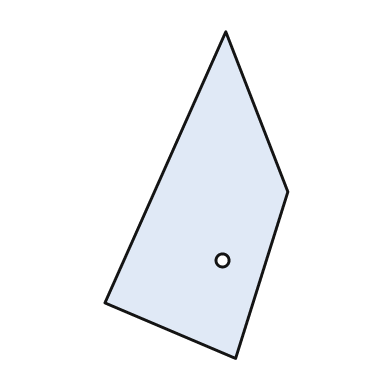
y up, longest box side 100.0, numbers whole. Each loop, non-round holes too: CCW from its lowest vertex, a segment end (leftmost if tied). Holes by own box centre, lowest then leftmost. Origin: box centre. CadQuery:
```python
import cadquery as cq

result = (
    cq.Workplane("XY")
    .moveTo(12.0, -50.0)
    .lineTo(28.0, 1.0)
    .lineTo(9.0, 50.0)
    .lineTo(-28.0, -33.0)
    .close()
    .moveTo(8.0, -20.0)
    .circle(2.0)
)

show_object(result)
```